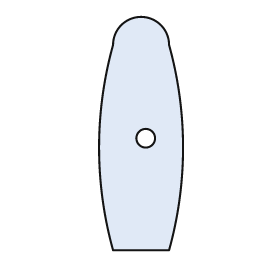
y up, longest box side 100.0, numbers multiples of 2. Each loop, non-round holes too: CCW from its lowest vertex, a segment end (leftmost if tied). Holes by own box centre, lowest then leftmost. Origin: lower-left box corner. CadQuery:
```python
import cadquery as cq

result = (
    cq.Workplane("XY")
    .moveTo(6.0, 0.0)
    .lineTo(30.0, 0.0)
    .threePointArc((36.0, 44.0), (30.0, 88.0))
    .threePointArc((18.0, 100.0), (6.0, 88.0))
    .threePointArc((0.0, 44.0), (6.0, 0.0))
    .close()
    .moveTo(20.0, 48.0)
    .circle(4.0)
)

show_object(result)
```